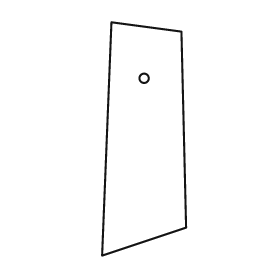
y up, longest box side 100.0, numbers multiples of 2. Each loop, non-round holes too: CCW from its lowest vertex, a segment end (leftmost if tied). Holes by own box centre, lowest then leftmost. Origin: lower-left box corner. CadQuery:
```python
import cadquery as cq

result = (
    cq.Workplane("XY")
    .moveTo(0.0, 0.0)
    .lineTo(36.0, 12.0)
    .lineTo(34.0, 96.0)
    .lineTo(4.0, 100.0)
    .close()
    .moveTo(18.0, 76.0)
    .circle(2.0)
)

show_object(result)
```